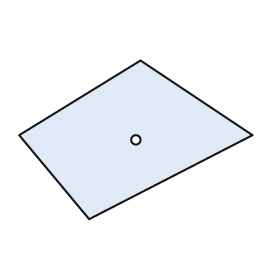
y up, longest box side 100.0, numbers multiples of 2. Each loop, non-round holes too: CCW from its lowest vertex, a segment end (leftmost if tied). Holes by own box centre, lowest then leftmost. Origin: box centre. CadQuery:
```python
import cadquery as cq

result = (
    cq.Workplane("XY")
    .moveTo(-20.0, -34.0)
    .lineTo(50.0, 2.0)
    .lineTo(2.0, 34.0)
    .lineTo(-50.0, 2.0)
    .close()
    .moveTo(0.0, 0.0)
    .circle(2.0)
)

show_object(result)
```